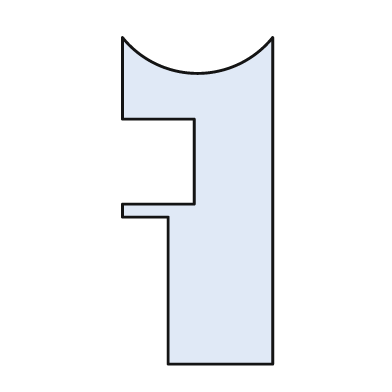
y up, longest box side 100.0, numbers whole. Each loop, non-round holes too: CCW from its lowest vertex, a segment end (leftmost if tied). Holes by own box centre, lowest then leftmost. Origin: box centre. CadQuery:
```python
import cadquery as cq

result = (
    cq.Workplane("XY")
    .moveTo(-9.0, -50.0)
    .lineTo(23.0, -50.0)
    .lineTo(23.0, 50.0)
    .threePointArc((0.0, 39.0), (-23.0, 50.0))
    .lineTo(-23.0, 25.0)
    .lineTo(-1.0, 25.0)
    .lineTo(-1.0, -1.0)
    .lineTo(-23.0, -1.0)
    .lineTo(-23.0, -5.0)
    .lineTo(-9.0, -5.0)
    .close()
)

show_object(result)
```